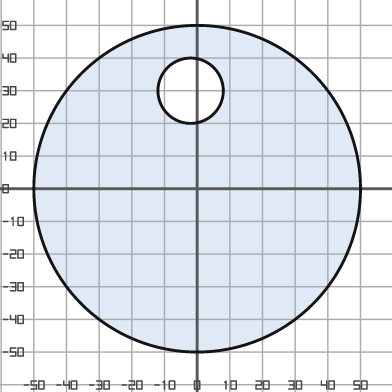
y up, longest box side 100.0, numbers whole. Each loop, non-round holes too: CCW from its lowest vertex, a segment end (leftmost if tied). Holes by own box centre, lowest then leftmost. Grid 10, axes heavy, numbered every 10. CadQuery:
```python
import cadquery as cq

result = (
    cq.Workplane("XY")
    .moveTo(0.0, 0.0)
    .circle(50.0)
    .moveTo(-2.0, 30.0)
    .circle(10.0)
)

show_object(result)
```